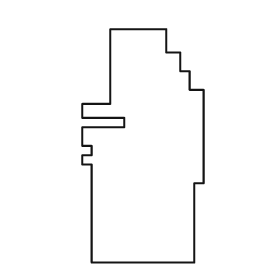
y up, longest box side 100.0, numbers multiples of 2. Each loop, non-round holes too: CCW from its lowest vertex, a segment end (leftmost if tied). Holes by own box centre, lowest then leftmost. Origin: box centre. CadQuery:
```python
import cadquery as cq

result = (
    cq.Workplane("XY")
    .moveTo(-22.0, -50.0)
    .lineTo(22.0, -50.0)
    .lineTo(22.0, -16.0)
    .lineTo(26.0, -16.0)
    .lineTo(26.0, 24.0)
    .lineTo(20.0, 24.0)
    .lineTo(20.0, 32.0)
    .lineTo(16.0, 32.0)
    .lineTo(16.0, 40.0)
    .lineTo(10.0, 40.0)
    .lineTo(10.0, 50.0)
    .lineTo(-14.0, 50.0)
    .lineTo(-14.0, 18.0)
    .lineTo(-26.0, 18.0)
    .lineTo(-26.0, 12.0)
    .lineTo(-8.0, 12.0)
    .lineTo(-8.0, 8.0)
    .lineTo(-26.0, 8.0)
    .lineTo(-26.0, 0.0)
    .lineTo(-22.0, 0.0)
    .lineTo(-22.0, -4.0)
    .lineTo(-26.0, -4.0)
    .lineTo(-26.0, -8.0)
    .lineTo(-22.0, -8.0)
    .close()
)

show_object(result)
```